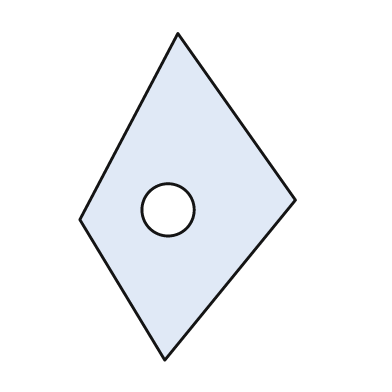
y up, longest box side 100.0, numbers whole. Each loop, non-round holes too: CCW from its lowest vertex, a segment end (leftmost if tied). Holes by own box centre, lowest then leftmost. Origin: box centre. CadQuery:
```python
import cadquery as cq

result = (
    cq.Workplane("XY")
    .moveTo(-7.0, -50.0)
    .lineTo(33.0, -1.0)
    .lineTo(-3.0, 50.0)
    .lineTo(-33.0, -7.0)
    .close()
    .moveTo(-6.0, -4.0)
    .circle(8.0)
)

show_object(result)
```